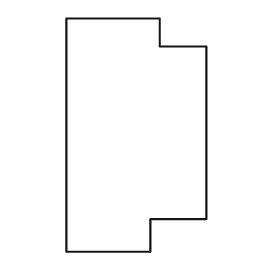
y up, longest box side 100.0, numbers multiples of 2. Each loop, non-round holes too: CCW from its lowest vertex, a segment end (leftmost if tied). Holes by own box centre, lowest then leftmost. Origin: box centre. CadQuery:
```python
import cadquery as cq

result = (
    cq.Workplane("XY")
    .moveTo(-30.0, -50.0)
    .lineTo(6.0, -50.0)
    .lineTo(6.0, -36.0)
    .lineTo(30.0, -36.0)
    .lineTo(30.0, 38.0)
    .lineTo(10.0, 38.0)
    .lineTo(10.0, 50.0)
    .lineTo(-30.0, 50.0)
    .close()
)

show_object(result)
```